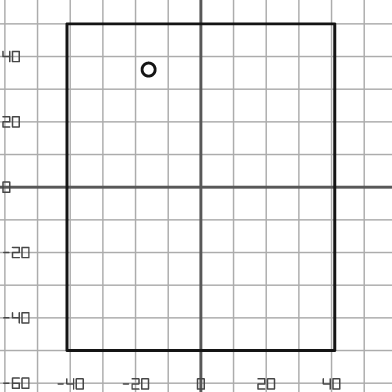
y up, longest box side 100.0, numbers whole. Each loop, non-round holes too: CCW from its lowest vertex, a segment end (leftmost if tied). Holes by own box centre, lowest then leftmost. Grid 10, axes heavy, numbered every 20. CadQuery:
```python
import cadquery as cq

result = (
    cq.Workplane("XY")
    .moveTo(-41.0, -50.0)
    .lineTo(41.0, -50.0)
    .lineTo(41.0, 50.0)
    .lineTo(-41.0, 50.0)
    .close()
    .moveTo(-16.0, 36.0)
    .circle(2.0)
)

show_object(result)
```